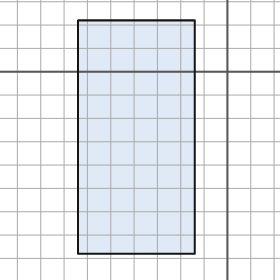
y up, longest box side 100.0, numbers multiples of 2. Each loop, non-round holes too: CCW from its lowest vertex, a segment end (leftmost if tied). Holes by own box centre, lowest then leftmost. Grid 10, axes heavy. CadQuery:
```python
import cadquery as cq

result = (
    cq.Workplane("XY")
    .moveTo(-64.0, -78.0)
    .lineTo(-14.0, -78.0)
    .lineTo(-14.0, 22.0)
    .lineTo(-64.0, 22.0)
    .close()
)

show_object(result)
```